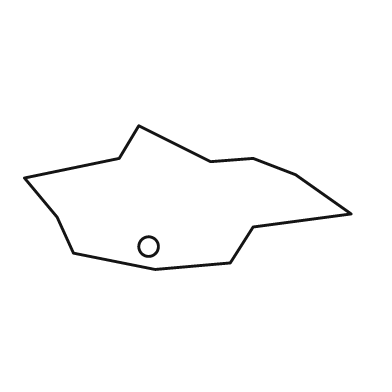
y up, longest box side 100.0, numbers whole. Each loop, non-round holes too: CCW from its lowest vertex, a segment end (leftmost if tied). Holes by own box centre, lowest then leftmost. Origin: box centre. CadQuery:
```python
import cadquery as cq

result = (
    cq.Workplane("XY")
    .moveTo(-10.0, -22.0)
    .lineTo(13.0, -20.0)
    .lineTo(20.0, -9.0)
    .lineTo(50.0, -5.0)
    .lineTo(33.0, 7.0)
    .lineTo(20.0, 12.0)
    .lineTo(7.0, 11.0)
    .lineTo(-15.0, 22.0)
    .lineTo(-21.0, 12.0)
    .lineTo(-50.0, 6.0)
    .lineTo(-40.0, -6.0)
    .lineTo(-35.0, -17.0)
    .close()
    .moveTo(-12.0, -15.0)
    .circle(3.0)
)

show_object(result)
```